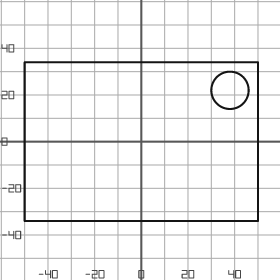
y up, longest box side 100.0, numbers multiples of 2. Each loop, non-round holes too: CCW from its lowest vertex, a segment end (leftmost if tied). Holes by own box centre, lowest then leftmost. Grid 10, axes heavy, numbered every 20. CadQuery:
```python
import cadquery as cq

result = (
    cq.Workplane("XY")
    .moveTo(-50.0, -34.0)
    .lineTo(50.0, -34.0)
    .lineTo(50.0, 34.0)
    .lineTo(-50.0, 34.0)
    .close()
    .moveTo(38.0, 22.0)
    .circle(8.0)
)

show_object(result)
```